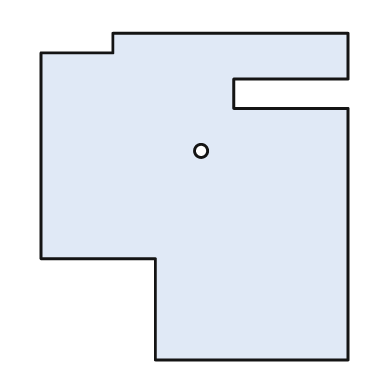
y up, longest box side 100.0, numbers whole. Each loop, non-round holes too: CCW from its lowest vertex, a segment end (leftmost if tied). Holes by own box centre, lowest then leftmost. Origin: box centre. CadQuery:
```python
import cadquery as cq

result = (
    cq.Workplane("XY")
    .moveTo(-12.0, -50.0)
    .lineTo(47.0, -50.0)
    .lineTo(47.0, 27.0)
    .lineTo(12.0, 27.0)
    .lineTo(12.0, 36.0)
    .lineTo(47.0, 36.0)
    .lineTo(47.0, 50.0)
    .lineTo(-25.0, 50.0)
    .lineTo(-25.0, 44.0)
    .lineTo(-47.0, 44.0)
    .lineTo(-47.0, -19.0)
    .lineTo(-12.0, -19.0)
    .close()
    .moveTo(2.0, 14.0)
    .circle(2.0)
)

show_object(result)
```